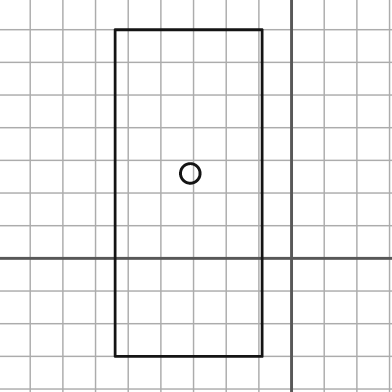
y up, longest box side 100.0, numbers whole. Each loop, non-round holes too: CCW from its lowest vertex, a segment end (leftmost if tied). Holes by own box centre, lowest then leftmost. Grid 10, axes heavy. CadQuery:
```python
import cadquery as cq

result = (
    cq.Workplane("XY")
    .moveTo(-54.0, -30.0)
    .lineTo(-9.0, -30.0)
    .lineTo(-9.0, 70.0)
    .lineTo(-54.0, 70.0)
    .close()
    .moveTo(-31.0, 26.0)
    .circle(3.0)
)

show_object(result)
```